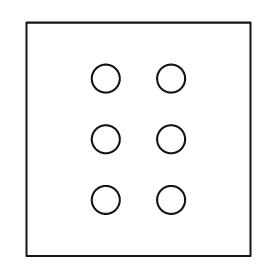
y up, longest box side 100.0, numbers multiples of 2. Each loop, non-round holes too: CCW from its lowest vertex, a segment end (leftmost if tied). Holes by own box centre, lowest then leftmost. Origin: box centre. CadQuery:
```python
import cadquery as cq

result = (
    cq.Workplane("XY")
    .moveTo(-48.0, -50.0)
    .lineTo(48.0, -50.0)
    .lineTo(48.0, 50.0)
    .lineTo(-48.0, 50.0)
    .close()
    .moveTo(-14.0, -26.0)
    .circle(6.0)
    .moveTo(14.0, -26.0)
    .circle(6.0)
    .moveTo(-14.0, 0.0)
    .circle(6.0)
    .moveTo(14.0, 0.0)
    .circle(6.0)
    .moveTo(-14.0, 26.0)
    .circle(6.0)
    .moveTo(14.0, 26.0)
    .circle(6.0)
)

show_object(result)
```